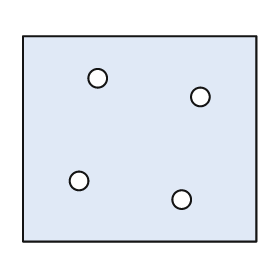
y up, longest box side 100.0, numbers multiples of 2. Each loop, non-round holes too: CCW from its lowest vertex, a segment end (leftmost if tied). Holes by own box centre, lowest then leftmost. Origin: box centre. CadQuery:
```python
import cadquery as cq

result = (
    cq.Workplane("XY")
    .moveTo(-50.0, -44.0)
    .lineTo(50.0, -44.0)
    .lineTo(50.0, 44.0)
    .lineTo(-50.0, 44.0)
    .close()
    .moveTo(18.0, -26.0)
    .circle(4.0)
    .moveTo(-26.0, -18.0)
    .circle(4.0)
    .moveTo(26.0, 18.0)
    .circle(4.0)
    .moveTo(-18.0, 26.0)
    .circle(4.0)
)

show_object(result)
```